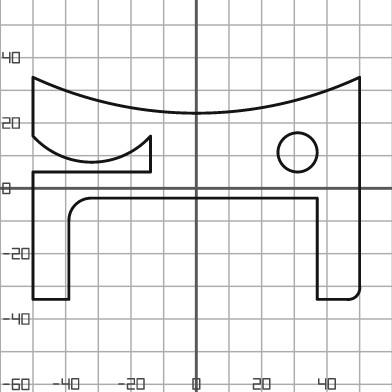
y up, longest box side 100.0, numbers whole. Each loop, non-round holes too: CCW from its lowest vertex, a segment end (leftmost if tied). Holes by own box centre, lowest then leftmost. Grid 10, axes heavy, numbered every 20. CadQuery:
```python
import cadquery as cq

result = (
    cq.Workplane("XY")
    .moveTo(-50.0, -34.0)
    .lineTo(-39.0, -34.0)
    .lineTo(-39.0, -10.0)
    .threePointArc((-37.0, -5.0), (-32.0, -3.0))
    .lineTo(37.0, -3.0)
    .lineTo(37.0, -34.0)
    .lineTo(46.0, -34.0)
    .threePointArc((49.0, -33.0), (50.0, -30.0))
    .lineTo(50.0, 34.0)
    .threePointArc((0.0, 23.0), (-50.0, 34.0))
    .lineTo(-50.0, 16.0)
    .threePointArc((-32.0, 8.0), (-14.0, 16.0))
    .lineTo(-14.0, 5.0)
    .lineTo(-50.0, 5.0)
    .close()
    .moveTo(31.0, 11.0)
    .circle(6.0)
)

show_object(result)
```